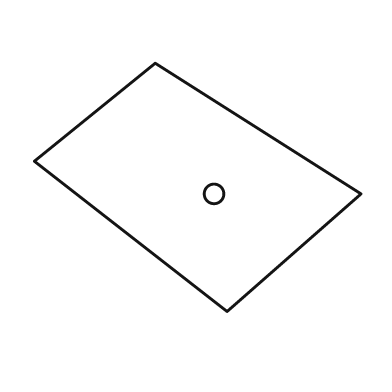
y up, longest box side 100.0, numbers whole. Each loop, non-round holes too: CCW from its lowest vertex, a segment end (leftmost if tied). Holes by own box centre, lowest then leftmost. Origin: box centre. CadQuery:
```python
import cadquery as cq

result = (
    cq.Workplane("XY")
    .moveTo(9.0, -38.0)
    .lineTo(50.0, -2.0)
    .lineTo(-13.0, 38.0)
    .lineTo(-50.0, 8.0)
    .close()
    .moveTo(5.0, -2.0)
    .circle(3.0)
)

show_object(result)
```